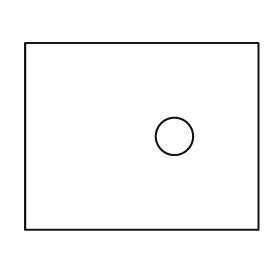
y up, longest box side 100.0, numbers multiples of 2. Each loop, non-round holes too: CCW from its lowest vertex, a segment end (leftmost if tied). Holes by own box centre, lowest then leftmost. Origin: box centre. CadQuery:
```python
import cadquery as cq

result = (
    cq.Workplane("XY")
    .moveTo(-50.0, -40.0)
    .lineTo(50.0, -40.0)
    .lineTo(50.0, 40.0)
    .lineTo(-50.0, 40.0)
    .close()
    .moveTo(14.0, 0.0)
    .circle(8.0)
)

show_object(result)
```